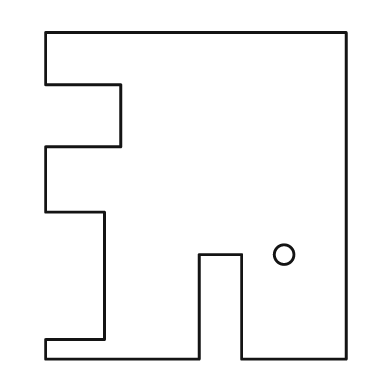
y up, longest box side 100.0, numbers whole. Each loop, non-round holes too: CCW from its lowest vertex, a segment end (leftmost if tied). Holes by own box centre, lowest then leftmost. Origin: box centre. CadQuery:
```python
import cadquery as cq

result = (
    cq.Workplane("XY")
    .moveTo(-46.0, -50.0)
    .lineTo(1.0, -50.0)
    .lineTo(1.0, -18.0)
    .lineTo(14.0, -18.0)
    .lineTo(14.0, -50.0)
    .lineTo(46.0, -50.0)
    .lineTo(46.0, 50.0)
    .lineTo(-46.0, 50.0)
    .lineTo(-46.0, 34.0)
    .lineTo(-23.0, 34.0)
    .lineTo(-23.0, 15.0)
    .lineTo(-46.0, 15.0)
    .lineTo(-46.0, -5.0)
    .lineTo(-28.0, -5.0)
    .lineTo(-28.0, -44.0)
    .lineTo(-46.0, -44.0)
    .close()
    .moveTo(27.0, -18.0)
    .circle(3.0)
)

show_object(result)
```